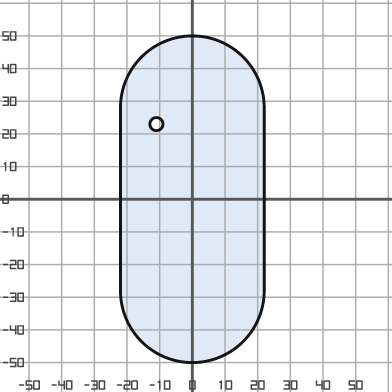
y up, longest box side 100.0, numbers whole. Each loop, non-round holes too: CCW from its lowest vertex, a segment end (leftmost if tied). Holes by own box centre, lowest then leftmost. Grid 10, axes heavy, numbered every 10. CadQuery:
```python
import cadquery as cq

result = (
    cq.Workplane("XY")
    .moveTo(-22.0, -28.0)
    .threePointArc((0.0, -50.0), (22.0, -28.0))
    .lineTo(22.0, 28.0)
    .threePointArc((0.0, 50.0), (-22.0, 28.0))
    .close()
    .moveTo(-11.0, 23.0)
    .circle(2.0)
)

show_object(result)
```